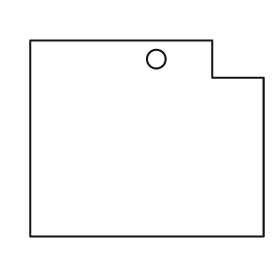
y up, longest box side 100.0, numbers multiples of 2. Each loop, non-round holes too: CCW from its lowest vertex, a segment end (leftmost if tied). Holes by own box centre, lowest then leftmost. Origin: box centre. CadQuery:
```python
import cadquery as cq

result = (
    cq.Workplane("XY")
    .moveTo(-50.0, -42.0)
    .lineTo(50.0, -42.0)
    .lineTo(50.0, 26.0)
    .lineTo(28.0, 26.0)
    .lineTo(28.0, 42.0)
    .lineTo(-50.0, 42.0)
    .close()
    .moveTo(4.0, 34.0)
    .circle(4.0)
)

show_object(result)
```